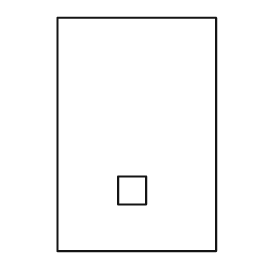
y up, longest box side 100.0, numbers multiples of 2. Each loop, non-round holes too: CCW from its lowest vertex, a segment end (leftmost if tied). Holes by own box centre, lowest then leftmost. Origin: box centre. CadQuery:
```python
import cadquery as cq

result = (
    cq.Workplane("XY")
    .moveTo(-34.0, -50.0)
    .lineTo(34.0, -50.0)
    .lineTo(34.0, 50.0)
    .lineTo(-34.0, 50.0)
    .close()
    .moveTo(-8.0, -30.0)
    .lineTo(4.0, -30.0)
    .lineTo(4.0, -18.0)
    .lineTo(-8.0, -18.0)
    .close()
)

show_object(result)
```